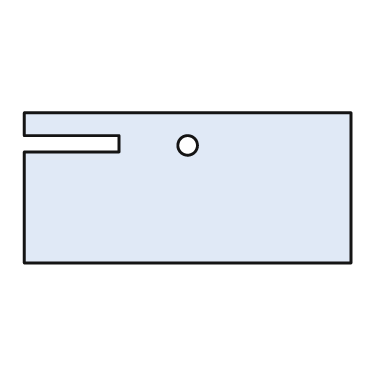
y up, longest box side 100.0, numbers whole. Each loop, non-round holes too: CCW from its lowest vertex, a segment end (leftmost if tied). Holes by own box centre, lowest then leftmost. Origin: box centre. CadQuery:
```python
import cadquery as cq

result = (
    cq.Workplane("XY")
    .moveTo(-50.0, -23.0)
    .lineTo(50.0, -23.0)
    .lineTo(50.0, 23.0)
    .lineTo(-50.0, 23.0)
    .lineTo(-50.0, 16.0)
    .lineTo(-21.0, 16.0)
    .lineTo(-21.0, 11.0)
    .lineTo(-50.0, 11.0)
    .close()
    .moveTo(0.0, 13.0)
    .circle(3.0)
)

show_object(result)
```